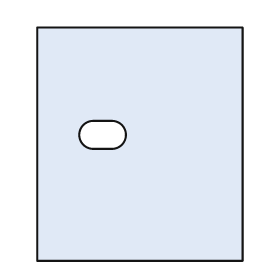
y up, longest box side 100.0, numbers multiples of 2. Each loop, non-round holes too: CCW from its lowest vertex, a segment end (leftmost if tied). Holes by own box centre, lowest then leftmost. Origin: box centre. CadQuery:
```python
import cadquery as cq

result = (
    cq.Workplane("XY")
    .moveTo(-44.0, -50.0)
    .lineTo(44.0, -50.0)
    .lineTo(44.0, 50.0)
    .lineTo(-44.0, 50.0)
    .close()
    .moveTo(-20.0, -2.0)
    .lineTo(-12.0, -2.0)
    .threePointArc((-6.0, 4.0), (-12.0, 10.0))
    .lineTo(-20.0, 10.0)
    .threePointArc((-26.0, 4.0), (-20.0, -2.0))
    .close()
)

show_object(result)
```